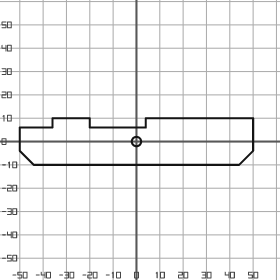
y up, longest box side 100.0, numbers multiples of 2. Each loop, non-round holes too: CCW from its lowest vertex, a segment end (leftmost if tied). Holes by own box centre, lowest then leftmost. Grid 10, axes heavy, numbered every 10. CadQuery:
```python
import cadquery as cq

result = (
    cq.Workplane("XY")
    .moveTo(-44.0, -10.0)
    .lineTo(44.0, -10.0)
    .lineTo(50.0, -4.0)
    .lineTo(50.0, 10.0)
    .lineTo(4.0, 10.0)
    .lineTo(4.0, 6.0)
    .lineTo(-20.0, 6.0)
    .lineTo(-20.0, 10.0)
    .lineTo(-36.0, 10.0)
    .lineTo(-36.0, 6.0)
    .lineTo(-50.0, 6.0)
    .lineTo(-50.0, -4.0)
    .close()
    .moveTo(0.0, 0.0)
    .circle(2.0)
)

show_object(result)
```